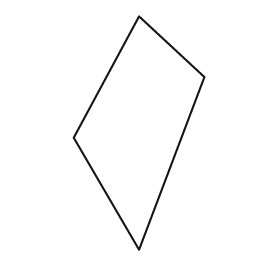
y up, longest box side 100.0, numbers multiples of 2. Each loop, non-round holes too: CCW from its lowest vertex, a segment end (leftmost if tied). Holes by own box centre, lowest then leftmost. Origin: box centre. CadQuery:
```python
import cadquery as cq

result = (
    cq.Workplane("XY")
    .moveTo(0.0, -50.0)
    .lineTo(28.0, 24.0)
    .lineTo(0.0, 50.0)
    .lineTo(-28.0, -2.0)
    .close()
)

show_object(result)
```